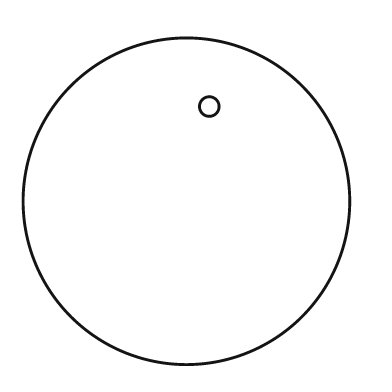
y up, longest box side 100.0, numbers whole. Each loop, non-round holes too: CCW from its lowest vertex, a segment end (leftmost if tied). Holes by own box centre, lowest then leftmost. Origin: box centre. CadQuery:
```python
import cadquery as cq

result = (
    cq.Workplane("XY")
    .moveTo(0.0, 0.0)
    .circle(50.0)
    .moveTo(7.0, 29.0)
    .circle(3.0)
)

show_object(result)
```